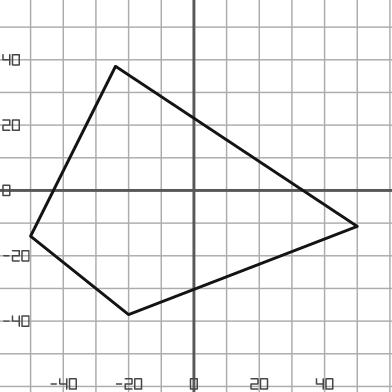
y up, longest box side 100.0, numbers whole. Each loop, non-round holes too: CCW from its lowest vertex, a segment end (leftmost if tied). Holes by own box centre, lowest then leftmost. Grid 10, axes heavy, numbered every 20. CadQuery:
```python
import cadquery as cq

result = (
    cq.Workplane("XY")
    .moveTo(-20.0, -38.0)
    .lineTo(50.0, -11.0)
    .lineTo(-24.0, 38.0)
    .lineTo(-50.0, -14.0)
    .close()
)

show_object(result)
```